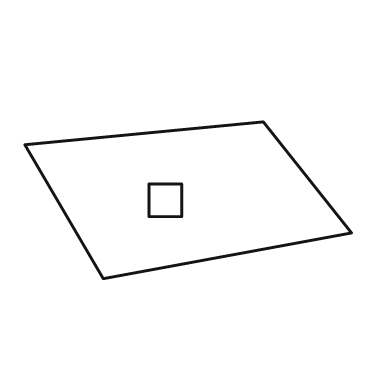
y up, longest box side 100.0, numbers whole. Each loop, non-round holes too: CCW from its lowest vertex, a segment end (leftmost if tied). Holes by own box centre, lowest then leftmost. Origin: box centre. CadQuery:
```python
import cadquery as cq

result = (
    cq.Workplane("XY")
    .moveTo(-26.0, -24.0)
    .lineTo(50.0, -10.0)
    .lineTo(23.0, 24.0)
    .lineTo(-50.0, 17.0)
    .close()
    .moveTo(-12.0, -5.0)
    .lineTo(-2.0, -5.0)
    .lineTo(-2.0, 5.0)
    .lineTo(-12.0, 5.0)
    .close()
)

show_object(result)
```